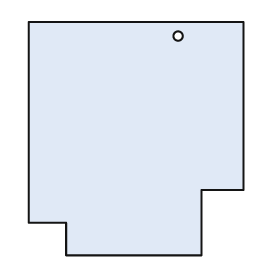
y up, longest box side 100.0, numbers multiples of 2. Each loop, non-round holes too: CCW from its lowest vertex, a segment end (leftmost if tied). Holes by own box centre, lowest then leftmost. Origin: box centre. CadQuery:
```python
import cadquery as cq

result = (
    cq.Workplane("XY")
    .moveTo(-30.0, -50.0)
    .lineTo(28.0, -50.0)
    .lineTo(28.0, -22.0)
    .lineTo(46.0, -22.0)
    .lineTo(46.0, 50.0)
    .lineTo(-46.0, 50.0)
    .lineTo(-46.0, -36.0)
    .lineTo(-30.0, -36.0)
    .close()
    .moveTo(18.0, 44.0)
    .circle(2.0)
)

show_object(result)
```